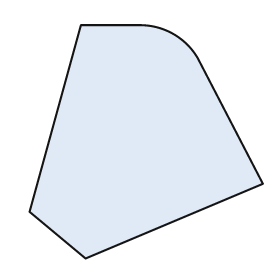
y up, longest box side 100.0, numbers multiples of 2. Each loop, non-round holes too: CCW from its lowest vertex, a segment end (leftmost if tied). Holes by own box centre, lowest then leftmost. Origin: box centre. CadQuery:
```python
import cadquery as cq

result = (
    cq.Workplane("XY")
    .moveTo(-26.0, -50.0)
    .lineTo(50.0, -18.0)
    .lineTo(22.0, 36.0)
    .threePointArc((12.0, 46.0), (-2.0, 50.0))
    .lineTo(-28.0, 50.0)
    .lineTo(-50.0, -30.0)
    .close()
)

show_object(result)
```